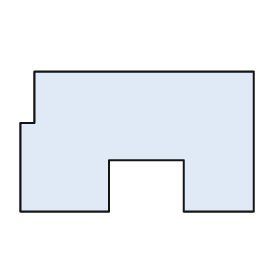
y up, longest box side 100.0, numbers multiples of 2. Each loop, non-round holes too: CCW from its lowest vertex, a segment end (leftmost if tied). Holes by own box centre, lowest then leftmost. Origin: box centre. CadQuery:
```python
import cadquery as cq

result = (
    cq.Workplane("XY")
    .moveTo(-50.0, -30.0)
    .lineTo(-12.0, -30.0)
    .lineTo(-12.0, -8.0)
    .lineTo(20.0, -8.0)
    .lineTo(20.0, -30.0)
    .lineTo(50.0, -30.0)
    .lineTo(50.0, 30.0)
    .lineTo(-44.0, 30.0)
    .lineTo(-44.0, 8.0)
    .lineTo(-50.0, 8.0)
    .close()
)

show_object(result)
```